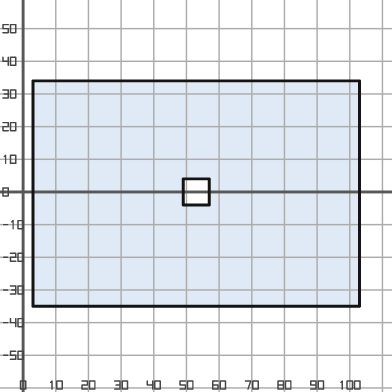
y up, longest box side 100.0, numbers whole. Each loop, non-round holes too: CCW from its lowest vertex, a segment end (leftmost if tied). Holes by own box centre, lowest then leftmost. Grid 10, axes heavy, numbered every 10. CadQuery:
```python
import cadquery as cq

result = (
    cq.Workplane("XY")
    .moveTo(3.0, -35.0)
    .lineTo(103.0, -35.0)
    .lineTo(103.0, 34.0)
    .lineTo(3.0, 34.0)
    .close()
    .moveTo(49.0, -4.0)
    .lineTo(57.0, -4.0)
    .lineTo(57.0, 4.0)
    .lineTo(49.0, 4.0)
    .close()
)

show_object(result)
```